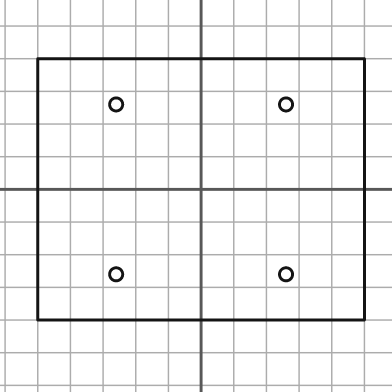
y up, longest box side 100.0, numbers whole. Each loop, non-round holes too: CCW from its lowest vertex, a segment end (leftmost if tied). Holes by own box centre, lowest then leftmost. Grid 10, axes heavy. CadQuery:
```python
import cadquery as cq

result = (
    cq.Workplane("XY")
    .moveTo(-50.0, -40.0)
    .lineTo(50.0, -40.0)
    .lineTo(50.0, 40.0)
    .lineTo(-50.0, 40.0)
    .close()
    .moveTo(-26.0, -26.0)
    .circle(2.0)
    .moveTo(26.0, -26.0)
    .circle(2.0)
    .moveTo(-26.0, 26.0)
    .circle(2.0)
    .moveTo(26.0, 26.0)
    .circle(2.0)
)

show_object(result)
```